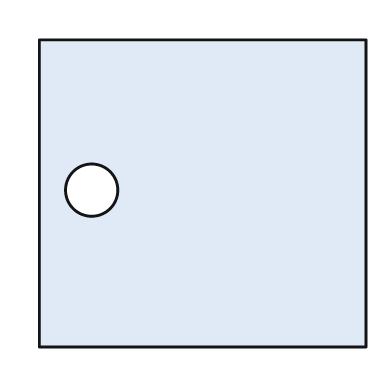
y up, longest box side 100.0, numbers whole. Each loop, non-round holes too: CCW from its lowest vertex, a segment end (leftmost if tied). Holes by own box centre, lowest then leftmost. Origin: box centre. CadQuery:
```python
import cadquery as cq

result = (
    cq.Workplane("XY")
    .moveTo(-50.0, -47.0)
    .lineTo(50.0, -47.0)
    .lineTo(50.0, 47.0)
    .lineTo(-50.0, 47.0)
    .close()
    .moveTo(-34.0, 1.0)
    .circle(8.0)
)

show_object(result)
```